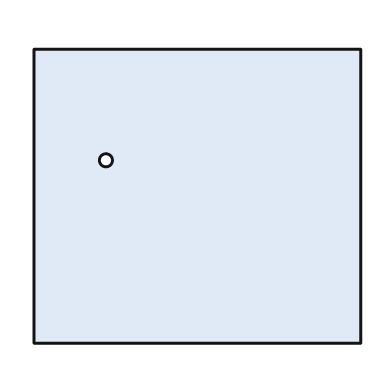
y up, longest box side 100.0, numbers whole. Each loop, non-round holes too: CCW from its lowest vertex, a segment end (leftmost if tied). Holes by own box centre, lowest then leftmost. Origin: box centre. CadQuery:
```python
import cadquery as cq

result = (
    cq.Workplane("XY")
    .moveTo(-50.0, -45.0)
    .lineTo(50.0, -45.0)
    .lineTo(50.0, 45.0)
    .lineTo(-50.0, 45.0)
    .close()
    .moveTo(-28.0, 11.0)
    .circle(2.0)
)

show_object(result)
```